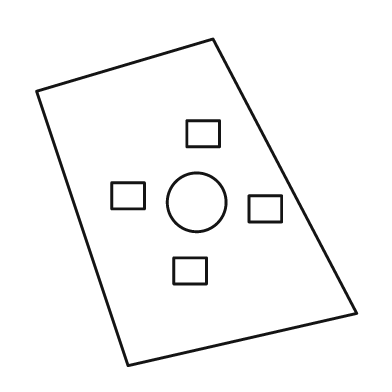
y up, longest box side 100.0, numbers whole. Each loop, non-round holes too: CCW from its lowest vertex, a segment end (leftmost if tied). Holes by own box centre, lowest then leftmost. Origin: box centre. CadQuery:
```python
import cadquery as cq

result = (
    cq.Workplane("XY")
    .moveTo(-21.0, -50.0)
    .lineTo(49.0, -34.0)
    .lineTo(5.0, 50.0)
    .lineTo(-49.0, 34.0)
    .close()
    .moveTo(-7.0, -25.0)
    .lineTo(3.0, -25.0)
    .lineTo(3.0, -17.0)
    .lineTo(-7.0, -17.0)
    .close()
    .moveTo(16.0, -6.0)
    .lineTo(26.0, -6.0)
    .lineTo(26.0, 2.0)
    .lineTo(16.0, 2.0)
    .close()
    .moveTo(0.0, 0.0)
    .circle(9.0)
    .moveTo(-26.0, -2.0)
    .lineTo(-16.0, -2.0)
    .lineTo(-16.0, 6.0)
    .lineTo(-26.0, 6.0)
    .close()
    .moveTo(-3.0, 17.0)
    .lineTo(7.0, 17.0)
    .lineTo(7.0, 25.0)
    .lineTo(-3.0, 25.0)
    .close()
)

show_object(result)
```